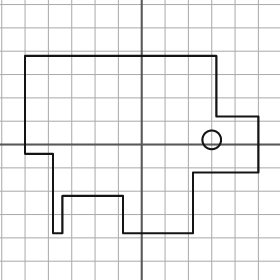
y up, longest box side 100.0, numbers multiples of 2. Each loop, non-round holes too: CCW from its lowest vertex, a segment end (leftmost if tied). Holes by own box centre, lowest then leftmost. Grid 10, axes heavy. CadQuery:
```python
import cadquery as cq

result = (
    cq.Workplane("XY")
    .moveTo(-38.0, -38.0)
    .lineTo(-34.0, -38.0)
    .lineTo(-34.0, -22.0)
    .lineTo(-8.0, -22.0)
    .lineTo(-8.0, -38.0)
    .lineTo(22.0, -38.0)
    .lineTo(22.0, -12.0)
    .lineTo(50.0, -12.0)
    .lineTo(50.0, 12.0)
    .lineTo(32.0, 12.0)
    .lineTo(32.0, 38.0)
    .lineTo(-50.0, 38.0)
    .lineTo(-50.0, -4.0)
    .lineTo(-38.0, -4.0)
    .close()
    .moveTo(30.0, 2.0)
    .circle(4.0)
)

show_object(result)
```